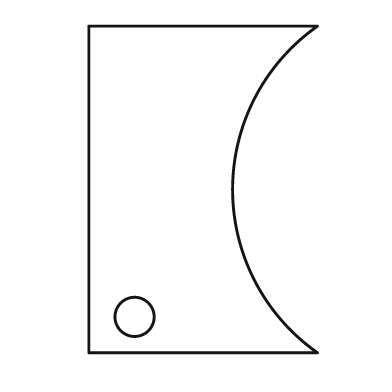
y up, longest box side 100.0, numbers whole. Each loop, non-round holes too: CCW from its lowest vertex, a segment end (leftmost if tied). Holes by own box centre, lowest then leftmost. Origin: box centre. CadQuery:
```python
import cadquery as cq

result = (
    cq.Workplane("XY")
    .moveTo(-35.0, -50.0)
    .lineTo(35.0, -50.0)
    .threePointArc((9.0, 0.0), (35.0, 50.0))
    .lineTo(-35.0, 50.0)
    .close()
    .moveTo(-21.0, -39.0)
    .circle(6.0)
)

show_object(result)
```